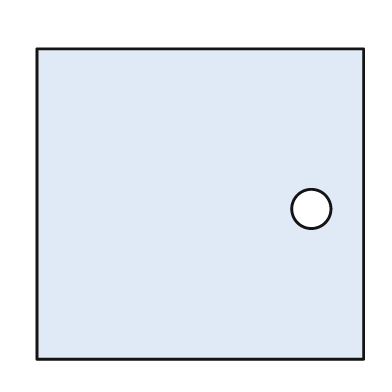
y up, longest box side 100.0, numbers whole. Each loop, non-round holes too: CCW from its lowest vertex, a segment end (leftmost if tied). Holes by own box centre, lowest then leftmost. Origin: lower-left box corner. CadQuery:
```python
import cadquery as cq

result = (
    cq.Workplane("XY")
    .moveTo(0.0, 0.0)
    .lineTo(100.0, 0.0)
    .lineTo(100.0, 95.0)
    .lineTo(0.0, 95.0)
    .close()
    .moveTo(84.0, 46.0)
    .circle(6.0)
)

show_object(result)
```